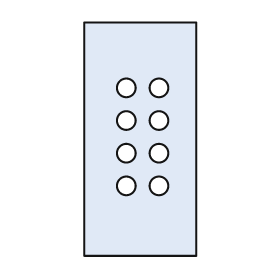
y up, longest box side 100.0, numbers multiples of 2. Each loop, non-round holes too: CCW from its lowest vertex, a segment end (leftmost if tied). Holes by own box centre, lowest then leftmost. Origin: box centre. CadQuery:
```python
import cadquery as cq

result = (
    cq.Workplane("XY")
    .moveTo(-24.0, -50.0)
    .lineTo(24.0, -50.0)
    .lineTo(24.0, 50.0)
    .lineTo(-24.0, 50.0)
    .close()
    .moveTo(-6.0, -20.0)
    .circle(4.0)
    .moveTo(8.0, -20.0)
    .circle(4.0)
    .moveTo(-6.0, -6.0)
    .circle(4.0)
    .moveTo(8.0, -6.0)
    .circle(4.0)
    .moveTo(-6.0, 8.0)
    .circle(4.0)
    .moveTo(8.0, 8.0)
    .circle(4.0)
    .moveTo(-6.0, 22.0)
    .circle(4.0)
    .moveTo(8.0, 22.0)
    .circle(4.0)
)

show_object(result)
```